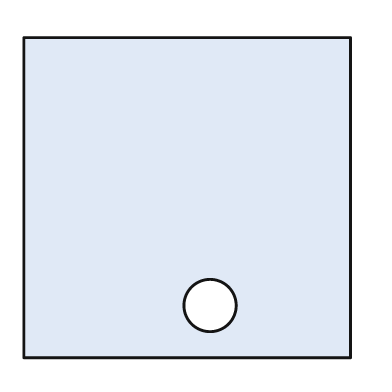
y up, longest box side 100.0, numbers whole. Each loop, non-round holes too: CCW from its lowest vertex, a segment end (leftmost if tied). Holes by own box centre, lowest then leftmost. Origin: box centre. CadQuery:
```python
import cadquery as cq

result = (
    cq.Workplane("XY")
    .moveTo(-50.0, -49.0)
    .lineTo(50.0, -49.0)
    .lineTo(50.0, 49.0)
    .lineTo(-50.0, 49.0)
    .close()
    .moveTo(7.0, -33.0)
    .circle(8.0)
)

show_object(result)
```